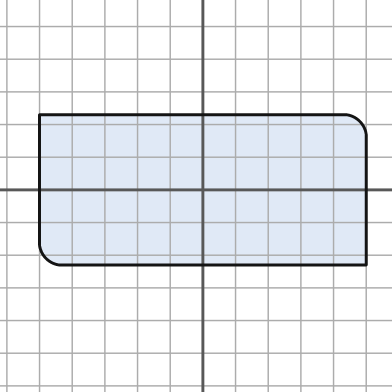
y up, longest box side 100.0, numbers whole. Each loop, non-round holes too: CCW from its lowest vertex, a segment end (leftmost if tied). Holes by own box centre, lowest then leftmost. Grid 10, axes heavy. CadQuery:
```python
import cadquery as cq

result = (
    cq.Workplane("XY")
    .moveTo(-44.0, -23.0)
    .lineTo(50.0, -23.0)
    .lineTo(50.0, 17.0)
    .threePointArc((48.0, 21.0), (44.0, 23.0))
    .lineTo(-50.0, 23.0)
    .lineTo(-50.0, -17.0)
    .threePointArc((-48.0, -21.0), (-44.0, -23.0))
    .close()
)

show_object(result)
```